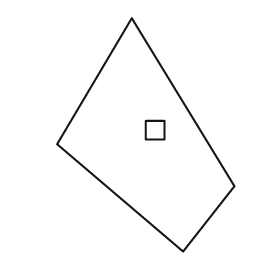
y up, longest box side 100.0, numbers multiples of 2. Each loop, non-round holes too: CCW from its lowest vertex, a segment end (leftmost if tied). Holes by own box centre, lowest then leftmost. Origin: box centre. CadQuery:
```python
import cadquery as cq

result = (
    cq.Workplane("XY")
    .moveTo(16.0, -50.0)
    .lineTo(38.0, -22.0)
    .lineTo(-6.0, 50.0)
    .lineTo(-38.0, -4.0)
    .close()
    .moveTo(0.0, -2.0)
    .lineTo(8.0, -2.0)
    .lineTo(8.0, 6.0)
    .lineTo(0.0, 6.0)
    .close()
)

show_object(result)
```